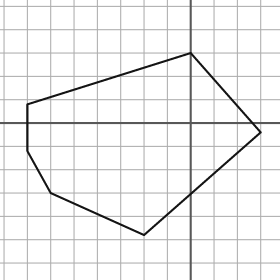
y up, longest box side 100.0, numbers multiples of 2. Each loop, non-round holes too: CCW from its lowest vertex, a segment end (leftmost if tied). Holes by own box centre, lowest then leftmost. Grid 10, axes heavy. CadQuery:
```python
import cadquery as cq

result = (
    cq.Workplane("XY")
    .moveTo(-20.0, -48.0)
    .lineTo(30.0, -4.0)
    .lineTo(0.0, 30.0)
    .lineTo(-70.0, 8.0)
    .lineTo(-70.0, -12.0)
    .lineTo(-60.0, -30.0)
    .close()
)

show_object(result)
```